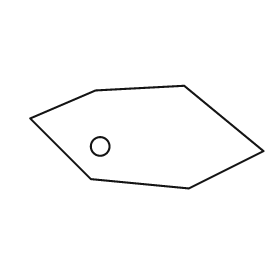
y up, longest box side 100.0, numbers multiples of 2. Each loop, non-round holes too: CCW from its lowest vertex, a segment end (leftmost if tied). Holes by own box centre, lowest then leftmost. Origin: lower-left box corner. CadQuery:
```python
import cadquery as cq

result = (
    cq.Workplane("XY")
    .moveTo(68.0, 0.0)
    .lineTo(100.0, 16.0)
    .lineTo(66.0, 44.0)
    .lineTo(28.0, 42.0)
    .lineTo(0.0, 30.0)
    .lineTo(26.0, 4.0)
    .close()
    .moveTo(30.0, 18.0)
    .circle(4.0)
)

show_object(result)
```